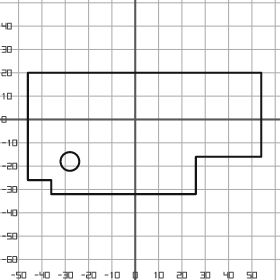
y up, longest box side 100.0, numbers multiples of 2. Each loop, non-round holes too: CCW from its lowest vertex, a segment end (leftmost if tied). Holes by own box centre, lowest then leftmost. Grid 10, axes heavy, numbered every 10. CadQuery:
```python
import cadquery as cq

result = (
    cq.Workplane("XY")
    .moveTo(-36.0, -32.0)
    .lineTo(26.0, -32.0)
    .lineTo(26.0, -16.0)
    .lineTo(54.0, -16.0)
    .lineTo(54.0, 20.0)
    .lineTo(-46.0, 20.0)
    .lineTo(-46.0, -26.0)
    .lineTo(-36.0, -26.0)
    .close()
    .moveTo(-28.0, -18.0)
    .circle(4.0)
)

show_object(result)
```